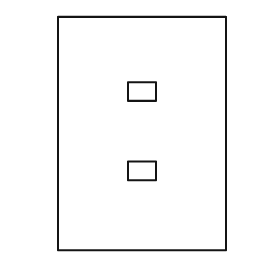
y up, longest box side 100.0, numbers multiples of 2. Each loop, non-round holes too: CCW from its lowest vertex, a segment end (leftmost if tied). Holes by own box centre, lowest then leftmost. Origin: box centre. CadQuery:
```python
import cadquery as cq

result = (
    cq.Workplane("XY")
    .moveTo(-36.0, -50.0)
    .lineTo(36.0, -50.0)
    .lineTo(36.0, 50.0)
    .lineTo(-36.0, 50.0)
    .close()
    .moveTo(-6.0, -20.0)
    .lineTo(6.0, -20.0)
    .lineTo(6.0, -12.0)
    .lineTo(-6.0, -12.0)
    .close()
    .moveTo(-6.0, 14.0)
    .lineTo(6.0, 14.0)
    .lineTo(6.0, 22.0)
    .lineTo(-6.0, 22.0)
    .close()
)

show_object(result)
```